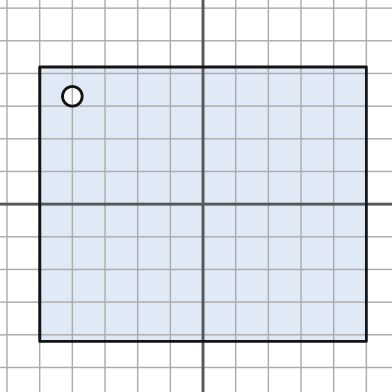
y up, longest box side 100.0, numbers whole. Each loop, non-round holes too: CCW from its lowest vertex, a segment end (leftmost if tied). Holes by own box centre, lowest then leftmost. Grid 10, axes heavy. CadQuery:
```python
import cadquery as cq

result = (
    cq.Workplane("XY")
    .moveTo(-50.0, -42.0)
    .lineTo(50.0, -42.0)
    .lineTo(50.0, 42.0)
    .lineTo(-50.0, 42.0)
    .close()
    .moveTo(-40.0, 33.0)
    .circle(3.0)
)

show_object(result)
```